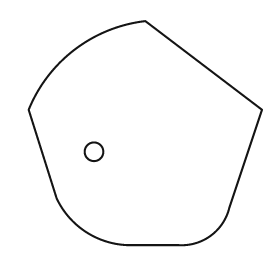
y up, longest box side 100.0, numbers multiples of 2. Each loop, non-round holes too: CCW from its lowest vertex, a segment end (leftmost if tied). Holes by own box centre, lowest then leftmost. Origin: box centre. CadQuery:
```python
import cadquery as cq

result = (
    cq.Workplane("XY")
    .moveTo(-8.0, -48.0)
    .lineTo(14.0, -48.0)
    .threePointArc((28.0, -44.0), (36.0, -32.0))
    .lineTo(50.0, 10.0)
    .lineTo(0.0, 48.0)
    .threePointArc((-30.0, 36.0), (-50.0, 10.0))
    .lineTo(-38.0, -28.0)
    .threePointArc((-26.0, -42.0), (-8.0, -48.0))
    .close()
    .moveTo(-22.0, -8.0)
    .circle(4.0)
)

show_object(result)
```